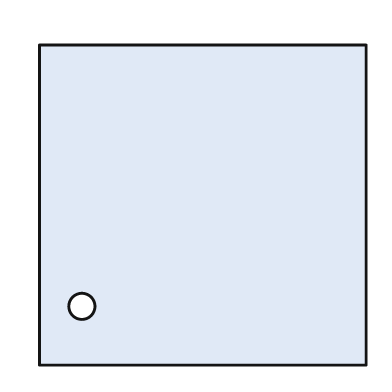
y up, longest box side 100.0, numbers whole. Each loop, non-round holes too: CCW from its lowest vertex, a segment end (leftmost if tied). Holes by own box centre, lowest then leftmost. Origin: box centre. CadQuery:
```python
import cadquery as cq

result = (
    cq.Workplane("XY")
    .moveTo(-50.0, -49.0)
    .lineTo(50.0, -49.0)
    .lineTo(50.0, 49.0)
    .lineTo(-50.0, 49.0)
    .close()
    .moveTo(-37.0, -31.0)
    .circle(4.0)
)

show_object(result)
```